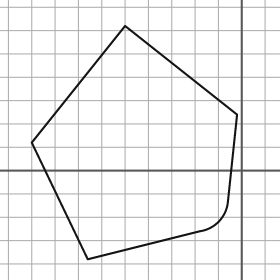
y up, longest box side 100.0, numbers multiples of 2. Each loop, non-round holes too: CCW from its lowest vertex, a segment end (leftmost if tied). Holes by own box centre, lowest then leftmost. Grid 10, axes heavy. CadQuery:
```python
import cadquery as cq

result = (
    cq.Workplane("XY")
    .moveTo(-66.0, -38.0)
    .lineTo(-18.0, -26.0)
    .threePointArc((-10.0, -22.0), (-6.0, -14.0))
    .lineTo(-2.0, 24.0)
    .lineTo(-50.0, 62.0)
    .lineTo(-90.0, 12.0)
    .close()
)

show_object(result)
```